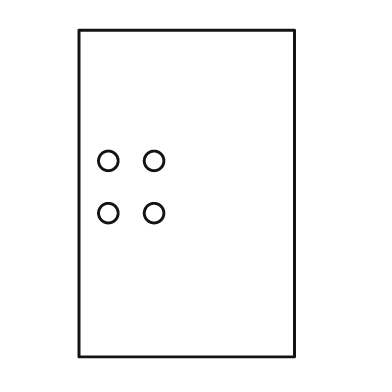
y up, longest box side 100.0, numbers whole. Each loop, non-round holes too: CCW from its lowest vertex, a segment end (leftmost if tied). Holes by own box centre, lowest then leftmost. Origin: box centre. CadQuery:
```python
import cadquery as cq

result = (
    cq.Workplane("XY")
    .moveTo(-33.0, -50.0)
    .lineTo(33.0, -50.0)
    .lineTo(33.0, 50.0)
    .lineTo(-33.0, 50.0)
    .close()
    .moveTo(-24.0, -6.0)
    .circle(3.0)
    .moveTo(-10.0, -6.0)
    .circle(3.0)
    .moveTo(-24.0, 10.0)
    .circle(3.0)
    .moveTo(-10.0, 10.0)
    .circle(3.0)
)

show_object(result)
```